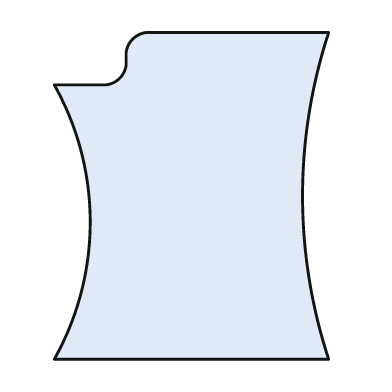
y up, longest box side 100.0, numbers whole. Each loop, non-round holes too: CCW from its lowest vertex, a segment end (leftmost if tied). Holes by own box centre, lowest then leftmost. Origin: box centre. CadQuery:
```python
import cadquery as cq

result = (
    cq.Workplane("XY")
    .moveTo(-42.0, -50.0)
    .lineTo(42.0, -50.0)
    .threePointArc((34.0, 0.0), (42.0, 50.0))
    .lineTo(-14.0, 50.0)
    .threePointArc((-18.0, 48.0), (-20.0, 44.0))
    .lineTo(-20.0, 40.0)
    .threePointArc((-22.0, 36.0), (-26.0, 34.0))
    .lineTo(-42.0, 34.0)
    .threePointArc((-31.0, -8.0), (-42.0, -50.0))
    .close()
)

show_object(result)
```